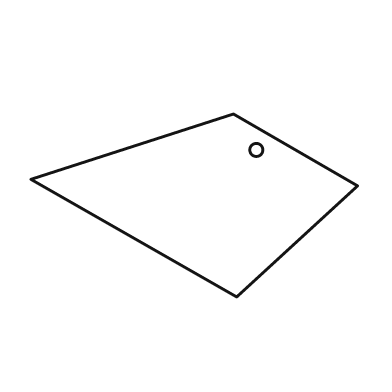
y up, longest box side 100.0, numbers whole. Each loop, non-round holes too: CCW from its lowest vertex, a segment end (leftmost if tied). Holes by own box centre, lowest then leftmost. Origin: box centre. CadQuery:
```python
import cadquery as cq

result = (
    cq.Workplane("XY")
    .moveTo(13.0, -28.0)
    .lineTo(50.0, 6.0)
    .lineTo(12.0, 28.0)
    .lineTo(-50.0, 8.0)
    .close()
    .moveTo(19.0, 17.0)
    .circle(2.0)
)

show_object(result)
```